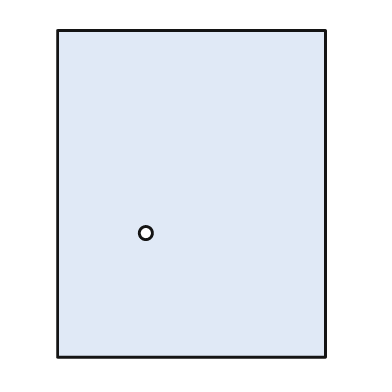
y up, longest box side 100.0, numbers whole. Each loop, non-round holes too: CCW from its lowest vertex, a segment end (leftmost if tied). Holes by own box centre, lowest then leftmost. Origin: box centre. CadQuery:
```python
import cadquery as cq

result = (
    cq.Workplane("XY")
    .moveTo(-41.0, -50.0)
    .lineTo(41.0, -50.0)
    .lineTo(41.0, 50.0)
    .lineTo(-41.0, 50.0)
    .close()
    .moveTo(-14.0, -12.0)
    .circle(2.0)
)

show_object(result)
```